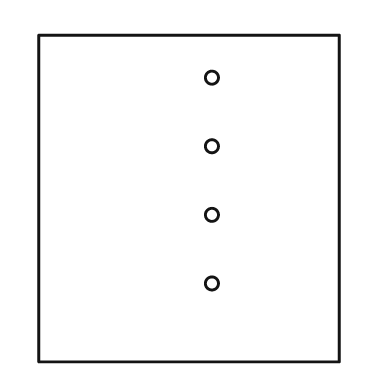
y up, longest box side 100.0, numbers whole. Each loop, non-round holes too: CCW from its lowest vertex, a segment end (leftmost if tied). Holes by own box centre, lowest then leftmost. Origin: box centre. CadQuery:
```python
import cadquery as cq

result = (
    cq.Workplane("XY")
    .moveTo(-46.0, -50.0)
    .lineTo(46.0, -50.0)
    .lineTo(46.0, 50.0)
    .lineTo(-46.0, 50.0)
    .close()
    .moveTo(7.0, -26.0)
    .circle(2.0)
    .moveTo(7.0, -5.0)
    .circle(2.0)
    .moveTo(7.0, 16.0)
    .circle(2.0)
    .moveTo(7.0, 37.0)
    .circle(2.0)
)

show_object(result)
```